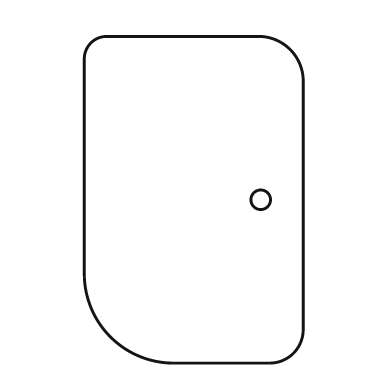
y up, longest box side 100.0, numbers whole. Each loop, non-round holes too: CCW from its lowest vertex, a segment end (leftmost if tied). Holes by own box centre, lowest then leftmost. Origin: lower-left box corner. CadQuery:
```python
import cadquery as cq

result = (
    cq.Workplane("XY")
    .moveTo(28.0, 0.0)
    .lineTo(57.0, 0.0)
    .threePointArc((64.0, 3.0), (67.0, 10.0))
    .lineTo(67.0, 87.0)
    .threePointArc((63.0, 96.0), (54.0, 100.0))
    .lineTo(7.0, 100.0)
    .threePointArc((2.0, 98.0), (0.0, 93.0))
    .lineTo(0.0, 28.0)
    .threePointArc((8.0, 8.0), (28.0, 0.0))
    .close()
    .moveTo(54.0, 50.0)
    .circle(3.0)
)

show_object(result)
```